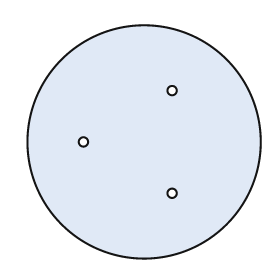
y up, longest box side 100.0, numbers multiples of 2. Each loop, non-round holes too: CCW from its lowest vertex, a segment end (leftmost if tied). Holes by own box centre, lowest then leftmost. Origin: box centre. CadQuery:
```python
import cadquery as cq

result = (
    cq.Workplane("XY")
    .moveTo(0.0, 0.0)
    .circle(50.0)
    .moveTo(12.0, -22.0)
    .circle(2.0)
    .moveTo(-26.0, 0.0)
    .circle(2.0)
    .moveTo(12.0, 22.0)
    .circle(2.0)
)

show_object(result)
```